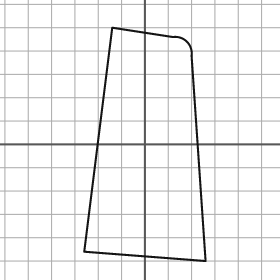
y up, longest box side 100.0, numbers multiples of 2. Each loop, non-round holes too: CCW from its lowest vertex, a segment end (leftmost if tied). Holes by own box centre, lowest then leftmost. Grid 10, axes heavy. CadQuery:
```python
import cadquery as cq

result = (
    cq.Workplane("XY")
    .moveTo(26.0, -50.0)
    .lineTo(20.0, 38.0)
    .threePointArc((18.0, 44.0), (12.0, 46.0))
    .lineTo(-14.0, 50.0)
    .lineTo(-26.0, -46.0)
    .close()
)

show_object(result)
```